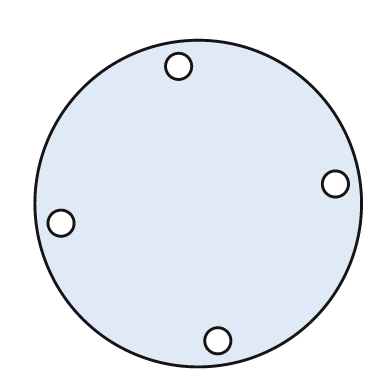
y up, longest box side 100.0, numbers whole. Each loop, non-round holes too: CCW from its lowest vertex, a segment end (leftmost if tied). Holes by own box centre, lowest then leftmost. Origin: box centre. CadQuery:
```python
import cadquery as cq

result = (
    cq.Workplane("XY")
    .moveTo(0.0, 0.0)
    .circle(50.0)
    .moveTo(6.0, -42.0)
    .circle(4.0)
    .moveTo(-42.0, -6.0)
    .circle(4.0)
    .moveTo(42.0, 6.0)
    .circle(4.0)
    .moveTo(-6.0, 42.0)
    .circle(4.0)
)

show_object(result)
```